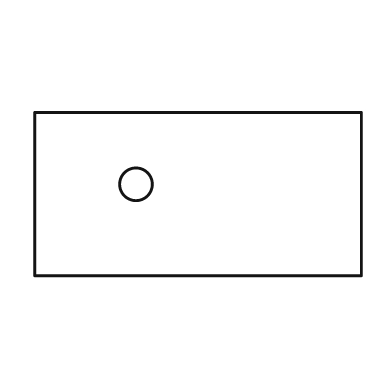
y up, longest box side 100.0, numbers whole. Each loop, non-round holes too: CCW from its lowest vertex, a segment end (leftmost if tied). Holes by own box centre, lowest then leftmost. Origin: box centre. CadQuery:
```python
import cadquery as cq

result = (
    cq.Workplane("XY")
    .moveTo(-50.0, -25.0)
    .lineTo(50.0, -25.0)
    .lineTo(50.0, 25.0)
    .lineTo(-50.0, 25.0)
    .close()
    .moveTo(-19.0, 3.0)
    .circle(5.0)
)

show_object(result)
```